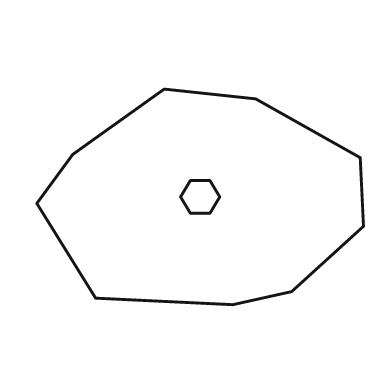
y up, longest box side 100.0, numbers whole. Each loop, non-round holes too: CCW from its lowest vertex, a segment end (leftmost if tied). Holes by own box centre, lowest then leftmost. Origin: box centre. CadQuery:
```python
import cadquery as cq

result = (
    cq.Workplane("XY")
    .moveTo(10.0, -33.0)
    .lineTo(28.0, -29.0)
    .lineTo(50.0, -9.0)
    .lineTo(49.0, 12.0)
    .lineTo(17.0, 30.0)
    .lineTo(-11.0, 33.0)
    .lineTo(-39.0, 13.0)
    .lineTo(-50.0, -2.0)
    .lineTo(-32.0, -31.0)
    .close()
    .moveTo(-3.0, -5.0)
    .lineTo(3.0, -5.0)
    .lineTo(6.0, 0.0)
    .lineTo(3.0, 5.0)
    .lineTo(-3.0, 5.0)
    .lineTo(-6.0, 0.0)
    .close()
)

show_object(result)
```